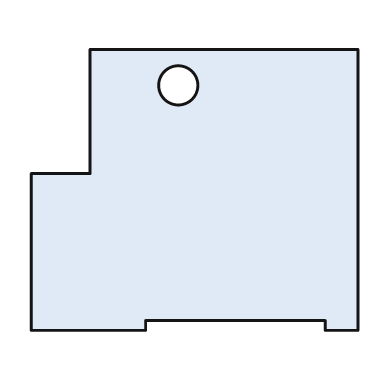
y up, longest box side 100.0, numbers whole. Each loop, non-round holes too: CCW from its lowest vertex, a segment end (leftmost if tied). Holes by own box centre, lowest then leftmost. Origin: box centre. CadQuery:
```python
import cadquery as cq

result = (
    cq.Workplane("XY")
    .moveTo(-50.0, -43.0)
    .lineTo(-15.0, -43.0)
    .lineTo(-15.0, -40.0)
    .lineTo(40.0, -40.0)
    .lineTo(40.0, -43.0)
    .lineTo(50.0, -43.0)
    .lineTo(50.0, 43.0)
    .lineTo(-32.0, 43.0)
    .lineTo(-32.0, 5.0)
    .lineTo(-50.0, 5.0)
    .close()
    .moveTo(-5.0, 32.0)
    .circle(6.0)
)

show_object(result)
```